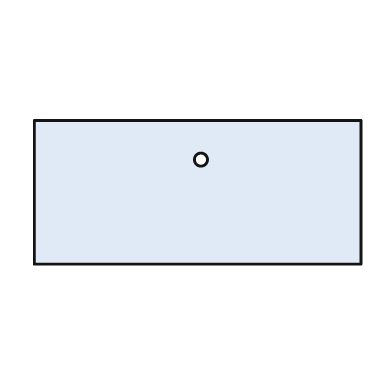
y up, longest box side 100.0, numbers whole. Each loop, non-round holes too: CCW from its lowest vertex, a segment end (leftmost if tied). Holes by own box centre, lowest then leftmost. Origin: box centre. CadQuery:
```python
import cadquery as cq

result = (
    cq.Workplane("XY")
    .moveTo(-50.0, -22.0)
    .lineTo(50.0, -22.0)
    .lineTo(50.0, 22.0)
    .lineTo(-50.0, 22.0)
    .close()
    .moveTo(1.0, 10.0)
    .circle(2.0)
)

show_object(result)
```